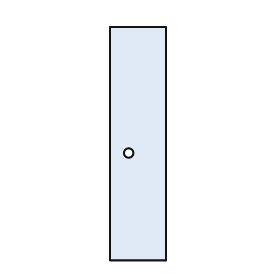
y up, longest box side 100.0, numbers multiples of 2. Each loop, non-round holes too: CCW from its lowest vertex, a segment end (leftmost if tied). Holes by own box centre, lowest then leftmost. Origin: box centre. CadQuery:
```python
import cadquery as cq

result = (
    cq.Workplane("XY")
    .moveTo(-12.0, -50.0)
    .lineTo(12.0, -50.0)
    .lineTo(12.0, 50.0)
    .lineTo(-12.0, 50.0)
    .close()
    .moveTo(-4.0, -4.0)
    .circle(2.0)
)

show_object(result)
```